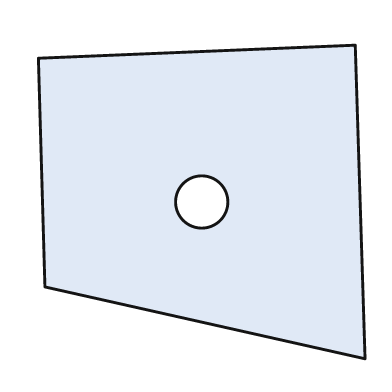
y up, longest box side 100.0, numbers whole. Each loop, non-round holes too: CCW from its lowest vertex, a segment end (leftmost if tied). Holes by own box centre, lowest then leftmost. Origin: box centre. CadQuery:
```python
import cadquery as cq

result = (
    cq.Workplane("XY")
    .moveTo(50.0, -48.0)
    .lineTo(47.0, 48.0)
    .lineTo(-50.0, 44.0)
    .lineTo(-48.0, -26.0)
    .close()
    .moveTo(0.0, 0.0)
    .circle(8.0)
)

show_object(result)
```